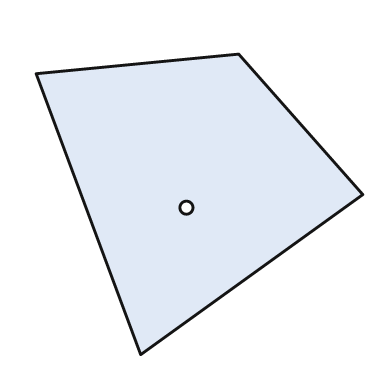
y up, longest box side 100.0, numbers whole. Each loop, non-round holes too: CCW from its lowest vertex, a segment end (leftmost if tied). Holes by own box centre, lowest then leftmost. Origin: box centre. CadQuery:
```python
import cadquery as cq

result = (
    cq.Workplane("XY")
    .moveTo(-18.0, -46.0)
    .lineTo(50.0, 3.0)
    .lineTo(12.0, 46.0)
    .lineTo(-50.0, 40.0)
    .close()
    .moveTo(-4.0, -1.0)
    .circle(2.0)
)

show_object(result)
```